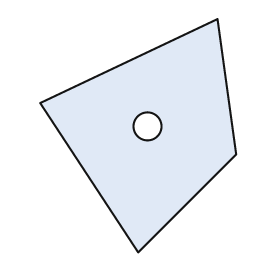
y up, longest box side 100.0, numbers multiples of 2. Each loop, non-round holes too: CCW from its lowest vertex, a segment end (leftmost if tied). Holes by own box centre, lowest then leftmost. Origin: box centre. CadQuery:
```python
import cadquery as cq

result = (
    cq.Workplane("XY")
    .moveTo(0.0, -50.0)
    .lineTo(42.0, -8.0)
    .lineTo(34.0, 50.0)
    .lineTo(-42.0, 14.0)
    .close()
    .moveTo(4.0, 4.0)
    .circle(6.0)
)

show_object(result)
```